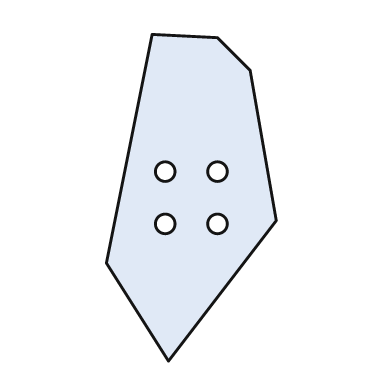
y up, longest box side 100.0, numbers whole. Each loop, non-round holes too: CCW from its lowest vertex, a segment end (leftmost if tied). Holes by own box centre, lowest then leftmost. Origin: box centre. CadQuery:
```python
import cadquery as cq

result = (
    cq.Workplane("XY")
    .moveTo(-7.0, -50.0)
    .lineTo(26.0, -7.0)
    .lineTo(18.0, 39.0)
    .lineTo(8.0, 49.0)
    .lineTo(-12.0, 50.0)
    .lineTo(-26.0, -20.0)
    .close()
    .moveTo(-8.0, -8.0)
    .circle(3.0)
    .moveTo(8.0, -8.0)
    .circle(3.0)
    .moveTo(-8.0, 8.0)
    .circle(3.0)
    .moveTo(8.0, 8.0)
    .circle(3.0)
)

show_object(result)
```